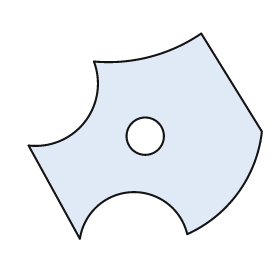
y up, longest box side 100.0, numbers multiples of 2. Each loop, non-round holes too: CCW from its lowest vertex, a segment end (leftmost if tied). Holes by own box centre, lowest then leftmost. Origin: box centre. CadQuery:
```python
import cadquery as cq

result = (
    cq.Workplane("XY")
    .moveTo(-28.0, -44.0)
    .threePointArc((-6.0, -24.0), (18.0, -42.0))
    .threePointArc((40.0, -24.0), (50.0, 2.0))
    .lineTo(24.0, 44.0)
    .threePointArc((2.0, 34.0), (-22.0, 32.0))
    .threePointArc((-26.0, 6.0), (-50.0, -4.0))
    .close()
    .moveTo(0.0, 0.0)
    .circle(8.0)
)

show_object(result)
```